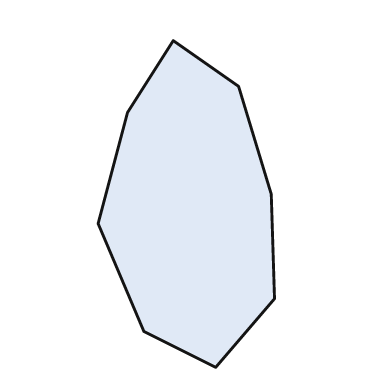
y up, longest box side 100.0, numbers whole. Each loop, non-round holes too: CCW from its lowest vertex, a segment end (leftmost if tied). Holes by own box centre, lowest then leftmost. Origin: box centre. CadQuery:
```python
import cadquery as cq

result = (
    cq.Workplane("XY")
    .moveTo(9.0, -50.0)
    .lineTo(27.0, -29.0)
    .lineTo(26.0, 3.0)
    .lineTo(16.0, 36.0)
    .lineTo(-4.0, 50.0)
    .lineTo(-18.0, 28.0)
    .lineTo(-27.0, -6.0)
    .lineTo(-13.0, -39.0)
    .close()
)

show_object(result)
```